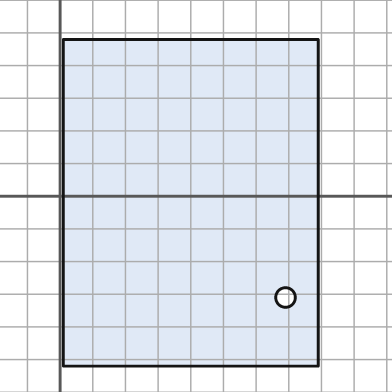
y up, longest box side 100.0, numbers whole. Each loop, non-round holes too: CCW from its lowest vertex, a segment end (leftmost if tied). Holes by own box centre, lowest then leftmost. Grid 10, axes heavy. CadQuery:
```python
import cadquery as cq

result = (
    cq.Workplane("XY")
    .moveTo(1.0, -52.0)
    .lineTo(79.0, -52.0)
    .lineTo(79.0, 48.0)
    .lineTo(1.0, 48.0)
    .close()
    .moveTo(69.0, -31.0)
    .circle(3.0)
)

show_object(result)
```